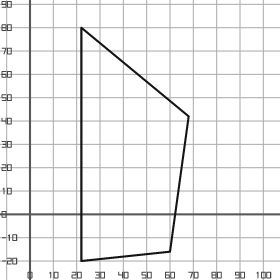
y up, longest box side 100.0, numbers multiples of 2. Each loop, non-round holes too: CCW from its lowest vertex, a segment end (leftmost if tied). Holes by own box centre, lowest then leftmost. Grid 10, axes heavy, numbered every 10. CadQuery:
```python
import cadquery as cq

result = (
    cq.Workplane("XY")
    .moveTo(22.0, -20.0)
    .lineTo(60.0, -16.0)
    .lineTo(68.0, 42.0)
    .lineTo(22.0, 80.0)
    .close()
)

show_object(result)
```